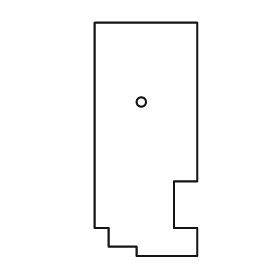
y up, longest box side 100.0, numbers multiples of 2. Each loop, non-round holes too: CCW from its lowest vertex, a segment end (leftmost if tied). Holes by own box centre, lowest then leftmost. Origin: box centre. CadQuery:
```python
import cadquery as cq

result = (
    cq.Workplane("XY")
    .moveTo(-4.0, -50.0)
    .lineTo(22.0, -50.0)
    .lineTo(22.0, -38.0)
    .lineTo(12.0, -38.0)
    .lineTo(12.0, -18.0)
    .lineTo(22.0, -18.0)
    .lineTo(22.0, 50.0)
    .lineTo(-22.0, 50.0)
    .lineTo(-22.0, -38.0)
    .lineTo(-16.0, -38.0)
    .lineTo(-16.0, -46.0)
    .lineTo(-4.0, -46.0)
    .close()
    .moveTo(-2.0, 16.0)
    .circle(2.0)
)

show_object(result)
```